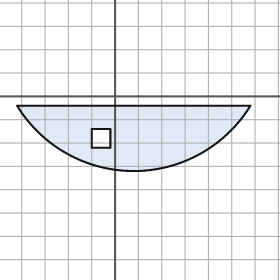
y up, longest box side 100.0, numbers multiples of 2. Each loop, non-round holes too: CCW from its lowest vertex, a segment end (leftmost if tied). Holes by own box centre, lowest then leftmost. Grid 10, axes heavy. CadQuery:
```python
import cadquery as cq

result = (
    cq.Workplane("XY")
    .moveTo(-42.0, -4.0)
    .threePointArc((8.0, -32.0), (58.0, -4.0))
    .close()
    .moveTo(-10.0, -22.0)
    .lineTo(-2.0, -22.0)
    .lineTo(-2.0, -14.0)
    .lineTo(-10.0, -14.0)
    .close()
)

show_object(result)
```